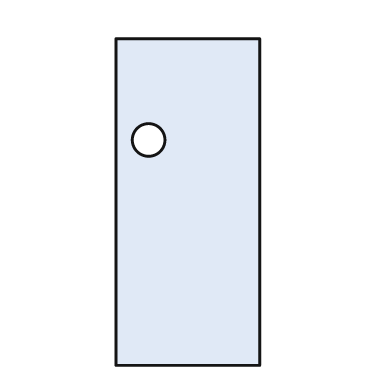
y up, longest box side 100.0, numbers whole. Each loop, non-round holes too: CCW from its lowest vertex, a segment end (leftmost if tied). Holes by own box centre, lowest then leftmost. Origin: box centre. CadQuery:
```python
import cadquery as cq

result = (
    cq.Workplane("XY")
    .moveTo(-22.0, -50.0)
    .lineTo(22.0, -50.0)
    .lineTo(22.0, 50.0)
    .lineTo(-22.0, 50.0)
    .close()
    .moveTo(-12.0, 19.0)
    .circle(5.0)
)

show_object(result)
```